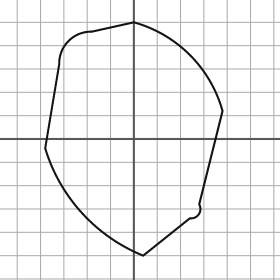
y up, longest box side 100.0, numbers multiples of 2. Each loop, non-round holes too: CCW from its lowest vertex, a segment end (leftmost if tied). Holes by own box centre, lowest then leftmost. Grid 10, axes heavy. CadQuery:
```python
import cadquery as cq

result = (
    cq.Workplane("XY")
    .moveTo(4.0, -50.0)
    .lineTo(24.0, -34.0)
    .threePointArc((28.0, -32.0), (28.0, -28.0))
    .lineTo(38.0, 12.0)
    .threePointArc((24.0, 36.0), (0.0, 50.0))
    .lineTo(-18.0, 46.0)
    .threePointArc((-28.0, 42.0), (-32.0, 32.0))
    .lineTo(-38.0, -4.0)
    .threePointArc((-22.0, -32.0), (4.0, -50.0))
    .close()
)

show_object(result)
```